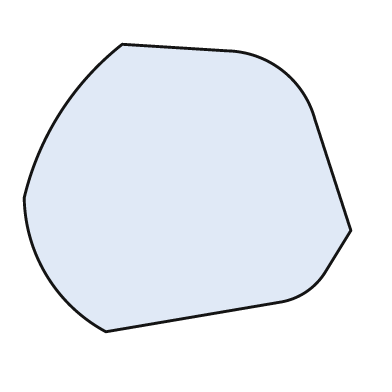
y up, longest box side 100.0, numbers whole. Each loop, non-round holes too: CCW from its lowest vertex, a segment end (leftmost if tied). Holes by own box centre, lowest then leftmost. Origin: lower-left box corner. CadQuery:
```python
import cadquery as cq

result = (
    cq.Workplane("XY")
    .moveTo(25.0, 0.0)
    .lineTo(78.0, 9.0)
    .threePointArc((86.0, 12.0), (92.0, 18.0))
    .lineTo(100.0, 31.0)
    .lineTo(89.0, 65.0)
    .threePointArc((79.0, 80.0), (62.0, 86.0))
    .lineTo(30.0, 88.0)
    .threePointArc((11.0, 67.0), (0.0, 41.0))
    .threePointArc((7.0, 17.0), (25.0, 0.0))
    .close()
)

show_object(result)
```